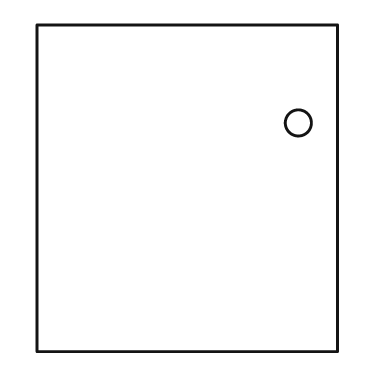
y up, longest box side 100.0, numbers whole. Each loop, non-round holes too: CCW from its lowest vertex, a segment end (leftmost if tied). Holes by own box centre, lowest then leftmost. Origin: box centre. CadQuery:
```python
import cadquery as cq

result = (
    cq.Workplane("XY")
    .moveTo(-46.0, -50.0)
    .lineTo(46.0, -50.0)
    .lineTo(46.0, 50.0)
    .lineTo(-46.0, 50.0)
    .close()
    .moveTo(34.0, 20.0)
    .circle(4.0)
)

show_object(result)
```